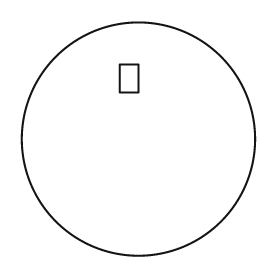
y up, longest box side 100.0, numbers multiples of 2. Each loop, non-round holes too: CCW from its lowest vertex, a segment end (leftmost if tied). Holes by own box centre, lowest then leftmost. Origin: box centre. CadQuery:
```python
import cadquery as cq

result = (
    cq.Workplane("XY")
    .moveTo(0.0, 0.0)
    .circle(50.0)
    .moveTo(-8.0, 20.0)
    .lineTo(0.0, 20.0)
    .lineTo(0.0, 32.0)
    .lineTo(-8.0, 32.0)
    .close()
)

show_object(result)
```